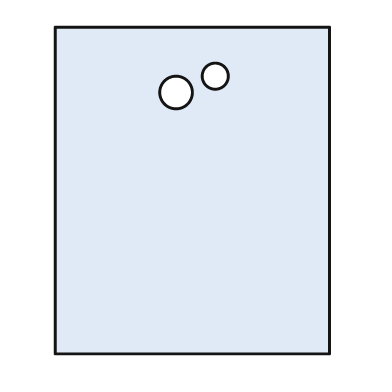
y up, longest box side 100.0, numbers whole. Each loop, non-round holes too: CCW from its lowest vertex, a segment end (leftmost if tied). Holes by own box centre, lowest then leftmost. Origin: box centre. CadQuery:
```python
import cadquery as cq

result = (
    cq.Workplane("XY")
    .moveTo(-42.0, -50.0)
    .lineTo(42.0, -50.0)
    .lineTo(42.0, 50.0)
    .lineTo(-42.0, 50.0)
    .close()
    .moveTo(-5.0, 30.0)
    .circle(5.0)
    .moveTo(7.0, 35.0)
    .circle(4.0)
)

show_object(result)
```